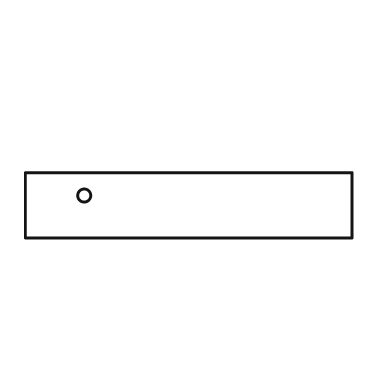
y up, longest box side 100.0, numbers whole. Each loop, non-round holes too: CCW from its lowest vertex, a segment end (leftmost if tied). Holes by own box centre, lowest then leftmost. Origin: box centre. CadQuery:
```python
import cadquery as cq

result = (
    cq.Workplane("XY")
    .moveTo(-50.0, -10.0)
    .lineTo(50.0, -10.0)
    .lineTo(50.0, 10.0)
    .lineTo(-50.0, 10.0)
    .close()
    .moveTo(-32.0, 3.0)
    .circle(2.0)
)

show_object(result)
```